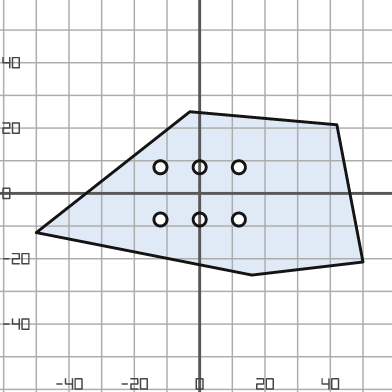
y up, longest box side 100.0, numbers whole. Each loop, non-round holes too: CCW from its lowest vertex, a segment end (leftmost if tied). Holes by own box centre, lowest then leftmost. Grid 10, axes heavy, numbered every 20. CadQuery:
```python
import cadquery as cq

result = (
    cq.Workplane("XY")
    .moveTo(16.0, -25.0)
    .lineTo(50.0, -21.0)
    .lineTo(42.0, 21.0)
    .lineTo(-3.0, 25.0)
    .lineTo(-50.0, -12.0)
    .close()
    .moveTo(-12.0, -8.0)
    .circle(2.0)
    .moveTo(0.0, -8.0)
    .circle(2.0)
    .moveTo(12.0, -8.0)
    .circle(2.0)
    .moveTo(-12.0, 8.0)
    .circle(2.0)
    .moveTo(0.0, 8.0)
    .circle(2.0)
    .moveTo(12.0, 8.0)
    .circle(2.0)
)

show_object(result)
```